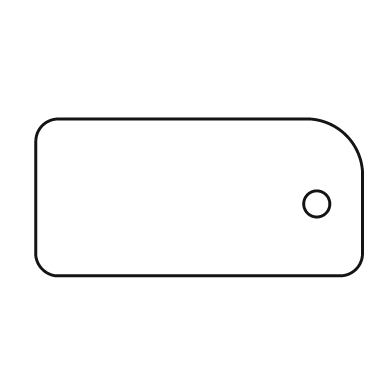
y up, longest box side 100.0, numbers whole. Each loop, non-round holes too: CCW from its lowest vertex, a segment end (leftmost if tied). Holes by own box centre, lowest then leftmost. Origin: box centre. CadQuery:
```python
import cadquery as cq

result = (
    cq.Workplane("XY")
    .moveTo(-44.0, -24.0)
    .lineTo(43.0, -24.0)
    .threePointArc((48.0, -22.0), (50.0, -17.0))
    .lineTo(50.0, 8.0)
    .threePointArc((45.0, 19.0), (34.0, 24.0))
    .lineTo(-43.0, 24.0)
    .threePointArc((-48.0, 22.0), (-50.0, 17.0))
    .lineTo(-50.0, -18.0)
    .threePointArc((-48.0, -22.0), (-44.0, -24.0))
    .close()
    .moveTo(36.0, -2.0)
    .circle(4.0)
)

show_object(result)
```